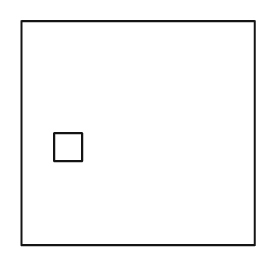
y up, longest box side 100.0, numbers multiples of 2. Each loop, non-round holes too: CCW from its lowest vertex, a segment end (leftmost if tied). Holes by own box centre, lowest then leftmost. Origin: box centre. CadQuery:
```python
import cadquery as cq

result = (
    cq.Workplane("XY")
    .moveTo(-50.0, -48.0)
    .lineTo(50.0, -48.0)
    .lineTo(50.0, 48.0)
    .lineTo(-50.0, 48.0)
    .close()
    .moveTo(-36.0, -12.0)
    .lineTo(-24.0, -12.0)
    .lineTo(-24.0, 0.0)
    .lineTo(-36.0, 0.0)
    .close()
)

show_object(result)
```